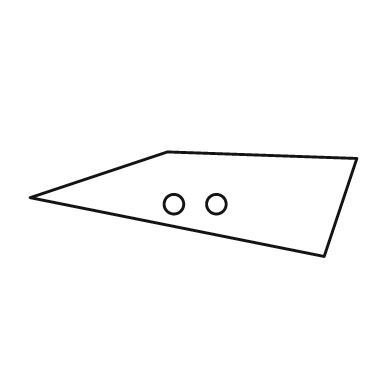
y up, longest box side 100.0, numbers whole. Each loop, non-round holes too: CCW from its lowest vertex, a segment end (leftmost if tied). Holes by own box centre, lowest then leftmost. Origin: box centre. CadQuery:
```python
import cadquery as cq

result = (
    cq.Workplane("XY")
    .moveTo(40.0, -16.0)
    .lineTo(50.0, 14.0)
    .lineTo(-8.0, 16.0)
    .lineTo(-50.0, 2.0)
    .close()
    .moveTo(-6.0, 0.0)
    .circle(3.0)
    .moveTo(7.0, 0.0)
    .circle(3.0)
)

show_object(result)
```